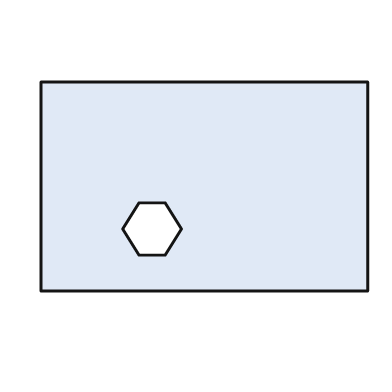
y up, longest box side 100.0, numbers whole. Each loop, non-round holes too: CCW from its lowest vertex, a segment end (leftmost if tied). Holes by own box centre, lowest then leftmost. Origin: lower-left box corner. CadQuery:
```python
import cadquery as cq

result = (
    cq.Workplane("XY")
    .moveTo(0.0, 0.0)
    .lineTo(100.0, 0.0)
    .lineTo(100.0, 64.0)
    .lineTo(0.0, 64.0)
    .close()
    .moveTo(30.0, 11.0)
    .lineTo(38.0, 11.0)
    .lineTo(43.0, 19.0)
    .lineTo(38.0, 27.0)
    .lineTo(30.0, 27.0)
    .lineTo(25.0, 19.0)
    .close()
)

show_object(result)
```